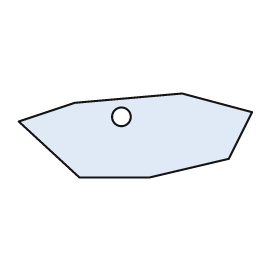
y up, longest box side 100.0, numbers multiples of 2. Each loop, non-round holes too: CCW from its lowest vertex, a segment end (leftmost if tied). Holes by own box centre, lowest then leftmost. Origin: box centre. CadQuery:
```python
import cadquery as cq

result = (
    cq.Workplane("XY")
    .moveTo(-24.0, -18.0)
    .lineTo(6.0, -18.0)
    .lineTo(40.0, -10.0)
    .lineTo(50.0, 10.0)
    .lineTo(20.0, 18.0)
    .lineTo(-26.0, 14.0)
    .lineTo(-50.0, 6.0)
    .close()
    .moveTo(-6.0, 8.0)
    .circle(4.0)
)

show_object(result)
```